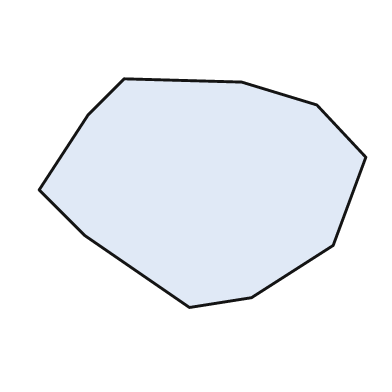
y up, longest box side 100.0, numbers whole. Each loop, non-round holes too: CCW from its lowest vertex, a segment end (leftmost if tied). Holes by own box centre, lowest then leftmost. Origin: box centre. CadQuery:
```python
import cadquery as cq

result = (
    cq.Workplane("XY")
    .moveTo(-4.0, -35.0)
    .lineTo(15.0, -32.0)
    .lineTo(40.0, -16.0)
    .lineTo(50.0, 11.0)
    .lineTo(35.0, 27.0)
    .lineTo(12.0, 34.0)
    .lineTo(-24.0, 35.0)
    .lineTo(-35.0, 24.0)
    .lineTo(-50.0, 1.0)
    .lineTo(-36.0, -13.0)
    .close()
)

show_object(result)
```